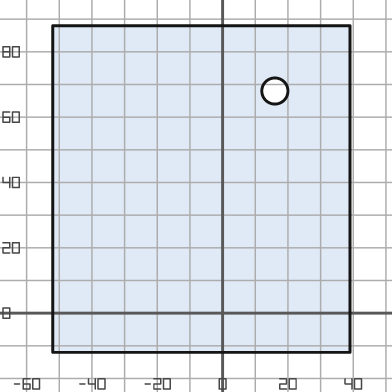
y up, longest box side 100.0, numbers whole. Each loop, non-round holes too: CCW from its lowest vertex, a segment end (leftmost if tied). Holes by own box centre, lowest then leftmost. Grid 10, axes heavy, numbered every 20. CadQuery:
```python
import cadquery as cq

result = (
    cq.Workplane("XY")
    .moveTo(-52.0, -12.0)
    .lineTo(39.0, -12.0)
    .lineTo(39.0, 88.0)
    .lineTo(-52.0, 88.0)
    .close()
    .moveTo(16.0, 68.0)
    .circle(4.0)
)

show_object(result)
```